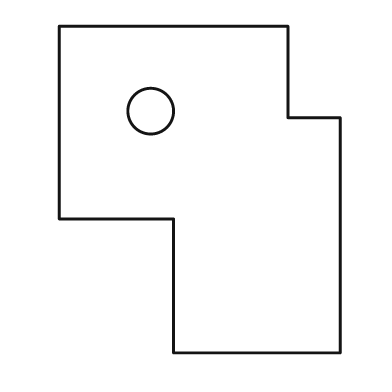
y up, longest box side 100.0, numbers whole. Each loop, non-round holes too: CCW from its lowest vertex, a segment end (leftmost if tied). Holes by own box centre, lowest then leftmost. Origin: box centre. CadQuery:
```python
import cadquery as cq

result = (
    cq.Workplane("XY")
    .moveTo(-8.0, -50.0)
    .lineTo(43.0, -50.0)
    .lineTo(43.0, 22.0)
    .lineTo(27.0, 22.0)
    .lineTo(27.0, 50.0)
    .lineTo(-43.0, 50.0)
    .lineTo(-43.0, -9.0)
    .lineTo(-8.0, -9.0)
    .close()
    .moveTo(-15.0, 24.0)
    .circle(7.0)
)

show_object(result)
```